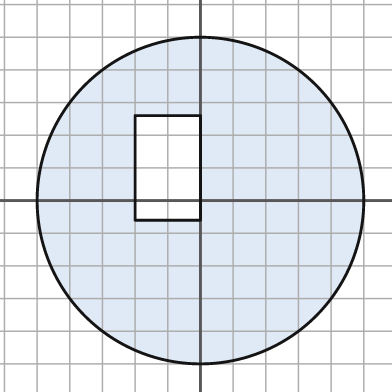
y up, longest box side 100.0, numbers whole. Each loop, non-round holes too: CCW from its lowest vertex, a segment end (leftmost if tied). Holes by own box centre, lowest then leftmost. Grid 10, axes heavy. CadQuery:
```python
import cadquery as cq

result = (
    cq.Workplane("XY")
    .moveTo(0.0, 0.0)
    .circle(50.0)
    .moveTo(-20.0, -6.0)
    .lineTo(0.0, -6.0)
    .lineTo(0.0, 26.0)
    .lineTo(-20.0, 26.0)
    .close()
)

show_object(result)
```